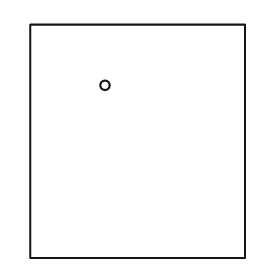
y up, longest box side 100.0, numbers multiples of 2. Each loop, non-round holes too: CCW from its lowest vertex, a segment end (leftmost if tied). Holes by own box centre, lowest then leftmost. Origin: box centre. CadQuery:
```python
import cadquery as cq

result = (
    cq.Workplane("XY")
    .moveTo(-46.0, -50.0)
    .lineTo(46.0, -50.0)
    .lineTo(46.0, 50.0)
    .lineTo(-46.0, 50.0)
    .close()
    .moveTo(-14.0, 24.0)
    .circle(2.0)
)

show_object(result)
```